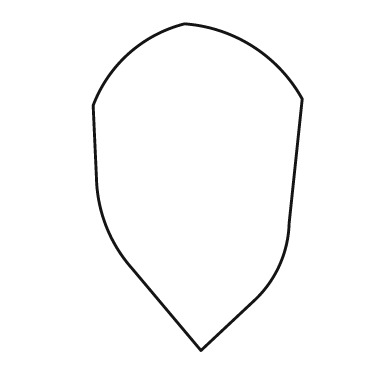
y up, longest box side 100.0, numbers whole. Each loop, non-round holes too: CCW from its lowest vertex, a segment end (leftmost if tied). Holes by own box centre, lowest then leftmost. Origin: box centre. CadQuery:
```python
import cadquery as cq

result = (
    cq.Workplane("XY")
    .moveTo(1.0, -50.0)
    .lineTo(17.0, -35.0)
    .threePointArc((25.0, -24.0), (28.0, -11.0))
    .lineTo(32.0, 27.0)
    .threePointArc((17.0, 43.0), (-4.0, 50.0))
    .threePointArc((-21.0, 41.0), (-32.0, 25.0))
    .lineTo(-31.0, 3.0)
    .threePointArc((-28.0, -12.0), (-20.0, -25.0))
    .close()
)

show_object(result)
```